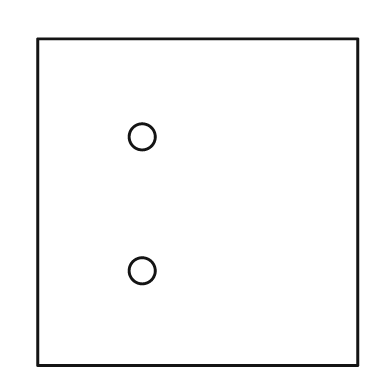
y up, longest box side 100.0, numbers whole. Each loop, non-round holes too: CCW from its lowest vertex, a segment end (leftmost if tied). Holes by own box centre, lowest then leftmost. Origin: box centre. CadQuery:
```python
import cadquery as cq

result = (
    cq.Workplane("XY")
    .moveTo(-49.0, -50.0)
    .lineTo(49.0, -50.0)
    .lineTo(49.0, 50.0)
    .lineTo(-49.0, 50.0)
    .close()
    .moveTo(-17.0, -21.0)
    .circle(4.0)
    .moveTo(-17.0, 20.0)
    .circle(4.0)
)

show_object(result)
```